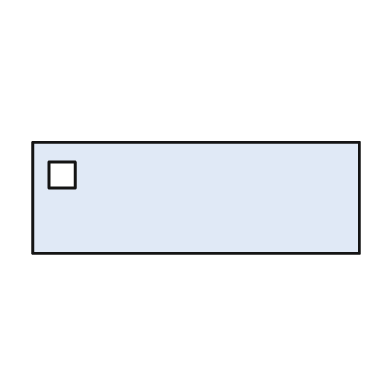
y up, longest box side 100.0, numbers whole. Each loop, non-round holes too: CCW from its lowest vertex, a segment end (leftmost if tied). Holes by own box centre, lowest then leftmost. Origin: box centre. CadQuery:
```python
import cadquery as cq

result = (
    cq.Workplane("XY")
    .moveTo(-50.0, -17.0)
    .lineTo(50.0, -17.0)
    .lineTo(50.0, 17.0)
    .lineTo(-50.0, 17.0)
    .close()
    .moveTo(-45.0, 3.0)
    .lineTo(-37.0, 3.0)
    .lineTo(-37.0, 11.0)
    .lineTo(-45.0, 11.0)
    .close()
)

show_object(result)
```